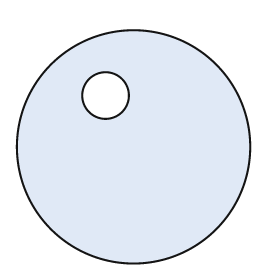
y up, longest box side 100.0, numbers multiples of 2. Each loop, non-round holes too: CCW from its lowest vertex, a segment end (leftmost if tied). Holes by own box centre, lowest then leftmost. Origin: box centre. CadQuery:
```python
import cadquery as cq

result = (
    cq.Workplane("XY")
    .moveTo(0.0, 0.0)
    .circle(50.0)
    .moveTo(-12.0, 22.0)
    .circle(10.0)
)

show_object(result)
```